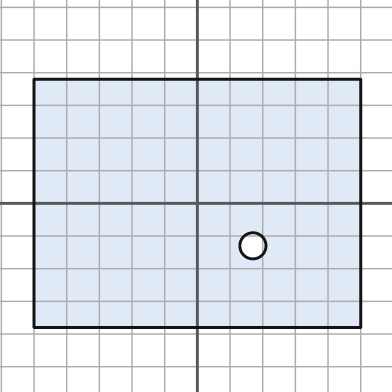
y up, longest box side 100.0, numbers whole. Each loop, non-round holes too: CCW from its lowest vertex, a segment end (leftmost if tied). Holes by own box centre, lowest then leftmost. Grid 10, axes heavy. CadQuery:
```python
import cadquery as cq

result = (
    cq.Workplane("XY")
    .moveTo(-50.0, -38.0)
    .lineTo(50.0, -38.0)
    .lineTo(50.0, 38.0)
    .lineTo(-50.0, 38.0)
    .close()
    .moveTo(17.0, -13.0)
    .circle(4.0)
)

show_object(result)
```